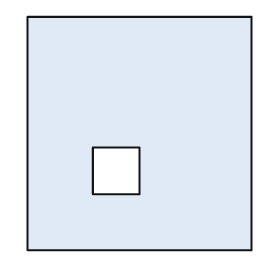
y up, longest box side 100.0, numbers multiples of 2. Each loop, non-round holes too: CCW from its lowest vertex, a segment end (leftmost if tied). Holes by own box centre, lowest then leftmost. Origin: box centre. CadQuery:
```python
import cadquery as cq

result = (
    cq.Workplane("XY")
    .moveTo(-48.0, -50.0)
    .lineTo(48.0, -50.0)
    .lineTo(48.0, 50.0)
    .lineTo(-48.0, 50.0)
    .close()
    .moveTo(-20.0, -26.0)
    .lineTo(0.0, -26.0)
    .lineTo(0.0, -6.0)
    .lineTo(-20.0, -6.0)
    .close()
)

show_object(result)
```